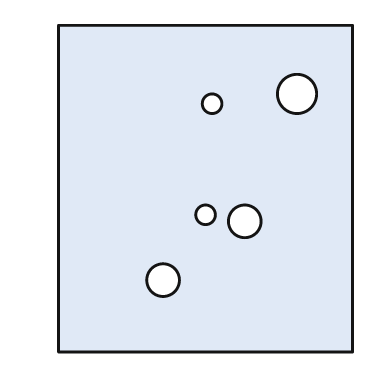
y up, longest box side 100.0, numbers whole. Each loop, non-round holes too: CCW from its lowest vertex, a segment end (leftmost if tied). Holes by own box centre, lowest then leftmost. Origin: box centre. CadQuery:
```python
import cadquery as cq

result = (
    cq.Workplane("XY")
    .moveTo(-45.0, -50.0)
    .lineTo(45.0, -50.0)
    .lineTo(45.0, 50.0)
    .lineTo(-45.0, 50.0)
    .close()
    .moveTo(-13.0, -28.0)
    .circle(5.0)
    .moveTo(12.0, -10.0)
    .circle(5.0)
    .moveTo(0.0, -8.0)
    .circle(3.0)
    .moveTo(2.0, 26.0)
    .circle(3.0)
    .moveTo(28.0, 29.0)
    .circle(6.0)
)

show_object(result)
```